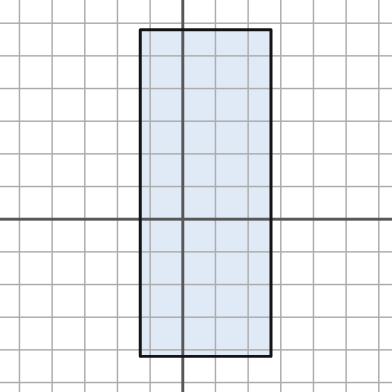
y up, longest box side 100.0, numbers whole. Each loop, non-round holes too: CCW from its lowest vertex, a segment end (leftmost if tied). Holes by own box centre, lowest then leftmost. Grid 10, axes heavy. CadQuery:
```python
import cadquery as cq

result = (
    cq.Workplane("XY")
    .moveTo(-13.0, -42.0)
    .lineTo(27.0, -42.0)
    .lineTo(27.0, 58.0)
    .lineTo(-13.0, 58.0)
    .close()
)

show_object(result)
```